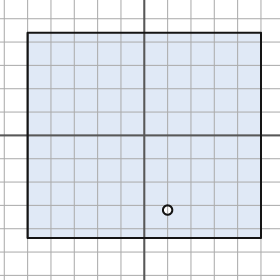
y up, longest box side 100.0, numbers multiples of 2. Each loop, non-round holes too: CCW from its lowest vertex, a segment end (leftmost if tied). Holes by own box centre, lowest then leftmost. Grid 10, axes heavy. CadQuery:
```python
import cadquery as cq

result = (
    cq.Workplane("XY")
    .moveTo(-50.0, -44.0)
    .lineTo(50.0, -44.0)
    .lineTo(50.0, 44.0)
    .lineTo(-50.0, 44.0)
    .close()
    .moveTo(10.0, -32.0)
    .circle(2.0)
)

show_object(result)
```